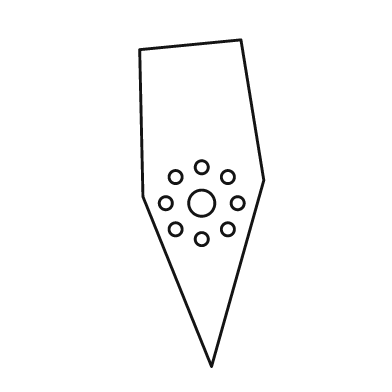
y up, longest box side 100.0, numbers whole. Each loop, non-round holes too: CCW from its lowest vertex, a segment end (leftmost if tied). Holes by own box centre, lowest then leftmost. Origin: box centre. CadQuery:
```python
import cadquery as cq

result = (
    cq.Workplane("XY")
    .moveTo(3.0, -50.0)
    .lineTo(19.0, 7.0)
    .lineTo(12.0, 50.0)
    .lineTo(-19.0, 47.0)
    .lineTo(-18.0, 2.0)
    .close()
    .moveTo(0.0, -11.0)
    .circle(2.0)
    .moveTo(-8.0, -8.0)
    .circle(2.0)
    .moveTo(8.0, -8.0)
    .circle(2.0)
    .moveTo(-11.0, 0.0)
    .circle(2.0)
    .moveTo(0.0, 0.0)
    .circle(4.0)
    .moveTo(11.0, 0.0)
    .circle(2.0)
    .moveTo(-8.0, 8.0)
    .circle(2.0)
    .moveTo(8.0, 8.0)
    .circle(2.0)
    .moveTo(0.0, 11.0)
    .circle(2.0)
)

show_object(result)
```